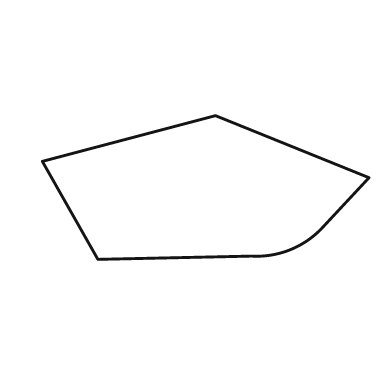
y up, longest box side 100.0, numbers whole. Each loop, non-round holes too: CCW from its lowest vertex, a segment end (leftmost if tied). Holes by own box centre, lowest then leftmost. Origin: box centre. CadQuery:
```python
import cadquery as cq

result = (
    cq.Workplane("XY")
    .moveTo(-33.0, -22.0)
    .lineTo(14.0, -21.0)
    .threePointArc((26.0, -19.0), (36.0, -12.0))
    .lineTo(50.0, 3.0)
    .lineTo(3.0, 22.0)
    .lineTo(-50.0, 8.0)
    .close()
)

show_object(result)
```